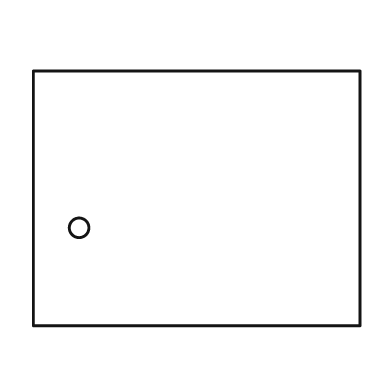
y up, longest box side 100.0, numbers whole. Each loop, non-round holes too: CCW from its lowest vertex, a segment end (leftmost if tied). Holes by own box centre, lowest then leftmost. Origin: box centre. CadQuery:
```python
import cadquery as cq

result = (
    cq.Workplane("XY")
    .moveTo(-50.0, -39.0)
    .lineTo(50.0, -39.0)
    .lineTo(50.0, 39.0)
    .lineTo(-50.0, 39.0)
    .close()
    .moveTo(-36.0, -9.0)
    .circle(3.0)
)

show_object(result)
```